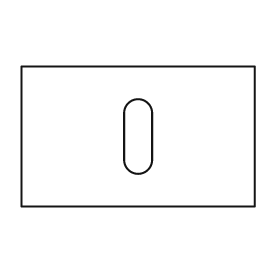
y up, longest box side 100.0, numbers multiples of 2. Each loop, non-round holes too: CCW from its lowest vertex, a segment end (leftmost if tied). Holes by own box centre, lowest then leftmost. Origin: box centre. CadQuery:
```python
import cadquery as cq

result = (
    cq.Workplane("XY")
    .moveTo(-50.0, -30.0)
    .lineTo(50.0, -30.0)
    .lineTo(50.0, 30.0)
    .lineTo(-50.0, 30.0)
    .close()
    .moveTo(-6.0, -10.0)
    .threePointArc((0.0, -16.0), (6.0, -10.0))
    .lineTo(6.0, 10.0)
    .threePointArc((0.0, 16.0), (-6.0, 10.0))
    .close()
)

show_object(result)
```